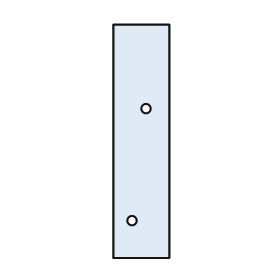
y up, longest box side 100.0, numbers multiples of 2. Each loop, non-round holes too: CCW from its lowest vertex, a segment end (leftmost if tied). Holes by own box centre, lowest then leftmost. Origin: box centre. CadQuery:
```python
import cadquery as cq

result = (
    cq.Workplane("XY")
    .moveTo(-12.0, -50.0)
    .lineTo(12.0, -50.0)
    .lineTo(12.0, 50.0)
    .lineTo(-12.0, 50.0)
    .close()
    .moveTo(-4.0, -34.0)
    .circle(2.0)
    .moveTo(2.0, 14.0)
    .circle(2.0)
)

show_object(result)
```